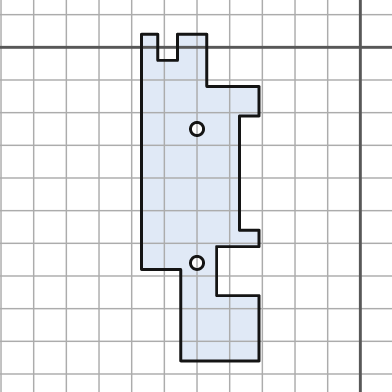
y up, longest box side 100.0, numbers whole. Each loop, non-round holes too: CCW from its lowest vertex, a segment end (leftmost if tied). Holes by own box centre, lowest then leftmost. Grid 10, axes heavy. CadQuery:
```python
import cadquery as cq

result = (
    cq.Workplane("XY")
    .moveTo(-55.0, -96.0)
    .lineTo(-31.0, -96.0)
    .lineTo(-31.0, -76.0)
    .lineTo(-44.0, -76.0)
    .lineTo(-44.0, -61.0)
    .lineTo(-31.0, -61.0)
    .lineTo(-31.0, -56.0)
    .lineTo(-37.0, -56.0)
    .lineTo(-37.0, -21.0)
    .lineTo(-31.0, -21.0)
    .lineTo(-31.0, -12.0)
    .lineTo(-47.0, -12.0)
    .lineTo(-47.0, 4.0)
    .lineTo(-56.0, 4.0)
    .lineTo(-56.0, -4.0)
    .lineTo(-62.0, -4.0)
    .lineTo(-62.0, 4.0)
    .lineTo(-67.0, 4.0)
    .lineTo(-67.0, -68.0)
    .lineTo(-55.0, -68.0)
    .close()
    .moveTo(-50.0, -66.0)
    .circle(2.0)
    .moveTo(-50.0, -25.0)
    .circle(2.0)
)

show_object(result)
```